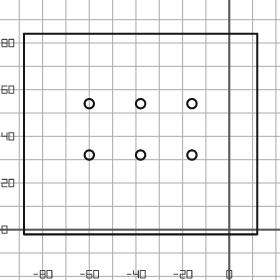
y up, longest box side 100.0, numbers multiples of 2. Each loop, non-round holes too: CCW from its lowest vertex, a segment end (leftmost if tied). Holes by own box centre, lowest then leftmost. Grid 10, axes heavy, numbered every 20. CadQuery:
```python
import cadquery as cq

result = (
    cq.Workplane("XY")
    .moveTo(-88.0, -2.0)
    .lineTo(12.0, -2.0)
    .lineTo(12.0, 84.0)
    .lineTo(-88.0, 84.0)
    .close()
    .moveTo(-60.0, 32.0)
    .circle(2.0)
    .moveTo(-38.0, 32.0)
    .circle(2.0)
    .moveTo(-16.0, 32.0)
    .circle(2.0)
    .moveTo(-60.0, 54.0)
    .circle(2.0)
    .moveTo(-38.0, 54.0)
    .circle(2.0)
    .moveTo(-16.0, 54.0)
    .circle(2.0)
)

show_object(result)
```